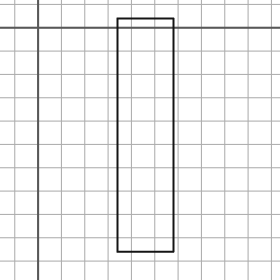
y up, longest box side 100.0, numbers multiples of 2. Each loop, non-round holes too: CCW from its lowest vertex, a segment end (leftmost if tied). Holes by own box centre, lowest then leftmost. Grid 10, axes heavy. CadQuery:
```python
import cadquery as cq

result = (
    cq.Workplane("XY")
    .moveTo(34.0, -96.0)
    .lineTo(58.0, -96.0)
    .lineTo(58.0, 4.0)
    .lineTo(34.0, 4.0)
    .close()
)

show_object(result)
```